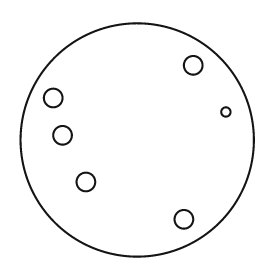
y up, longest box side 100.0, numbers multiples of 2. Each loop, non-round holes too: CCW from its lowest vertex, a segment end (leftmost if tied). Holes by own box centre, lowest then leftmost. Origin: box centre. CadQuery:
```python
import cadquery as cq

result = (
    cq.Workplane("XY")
    .moveTo(0.0, 0.0)
    .circle(50.0)
    .moveTo(20.0, -34.0)
    .circle(4.0)
    .moveTo(-22.0, -18.0)
    .circle(4.0)
    .moveTo(-32.0, 2.0)
    .circle(4.0)
    .moveTo(38.0, 12.0)
    .circle(2.0)
    .moveTo(-36.0, 18.0)
    .circle(4.0)
    .moveTo(24.0, 32.0)
    .circle(4.0)
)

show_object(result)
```